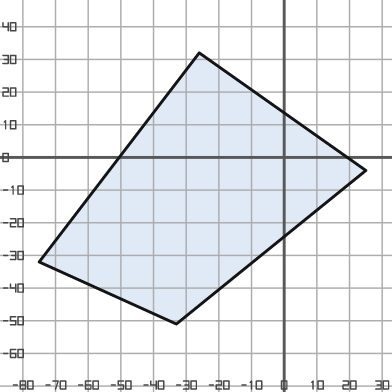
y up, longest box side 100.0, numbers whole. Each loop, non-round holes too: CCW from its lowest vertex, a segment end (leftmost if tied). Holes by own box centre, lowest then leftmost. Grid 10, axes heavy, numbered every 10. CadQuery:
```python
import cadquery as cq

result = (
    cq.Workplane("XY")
    .moveTo(-33.0, -51.0)
    .lineTo(25.0, -4.0)
    .lineTo(-26.0, 32.0)
    .lineTo(-75.0, -32.0)
    .close()
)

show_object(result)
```